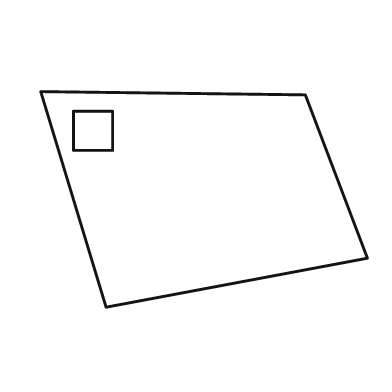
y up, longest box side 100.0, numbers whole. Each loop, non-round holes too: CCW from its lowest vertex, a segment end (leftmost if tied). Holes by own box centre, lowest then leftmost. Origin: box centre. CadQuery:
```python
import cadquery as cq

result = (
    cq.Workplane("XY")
    .moveTo(-30.0, -33.0)
    .lineTo(50.0, -18.0)
    .lineTo(31.0, 32.0)
    .lineTo(-50.0, 33.0)
    .close()
    .moveTo(-40.0, 15.0)
    .lineTo(-28.0, 15.0)
    .lineTo(-28.0, 27.0)
    .lineTo(-40.0, 27.0)
    .close()
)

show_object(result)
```